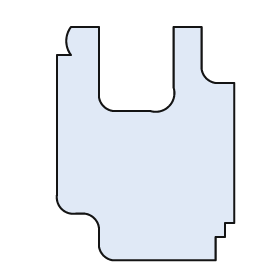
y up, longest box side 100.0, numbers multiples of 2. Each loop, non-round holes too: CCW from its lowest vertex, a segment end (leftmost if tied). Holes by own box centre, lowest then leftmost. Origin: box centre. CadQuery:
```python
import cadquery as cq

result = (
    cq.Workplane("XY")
    .moveTo(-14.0, -50.0)
    .lineTo(30.0, -50.0)
    .lineTo(30.0, -40.0)
    .lineTo(34.0, -40.0)
    .lineTo(34.0, -34.0)
    .lineTo(38.0, -34.0)
    .lineTo(38.0, 26.0)
    .lineTo(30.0, 26.0)
    .threePointArc((26.0, 28.0), (24.0, 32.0))
    .lineTo(24.0, 50.0)
    .lineTo(12.0, 50.0)
    .lineTo(12.0, 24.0)
    .threePointArc((10.0, 16.0), (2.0, 14.0))
    .lineTo(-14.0, 14.0)
    .threePointArc((-18.0, 16.0), (-20.0, 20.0))
    .lineTo(-20.0, 50.0)
    .lineTo(-32.0, 50.0)
    .threePointArc((-34.0, 44.0), (-32.0, 38.0))
    .lineTo(-38.0, 38.0)
    .lineTo(-38.0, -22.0)
    .threePointArc((-36.0, -28.0), (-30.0, -30.0))
    .lineTo(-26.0, -30.0)
    .threePointArc((-22.0, -32.0), (-20.0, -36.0))
    .lineTo(-20.0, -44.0)
    .threePointArc((-18.0, -48.0), (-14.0, -50.0))
    .close()
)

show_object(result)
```